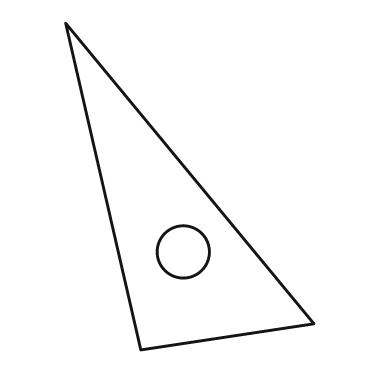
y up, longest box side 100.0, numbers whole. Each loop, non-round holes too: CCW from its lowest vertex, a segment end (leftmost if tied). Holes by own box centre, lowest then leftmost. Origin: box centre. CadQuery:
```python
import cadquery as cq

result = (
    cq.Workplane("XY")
    .moveTo(-15.0, -50.0)
    .lineTo(38.0, -42.0)
    .lineTo(-38.0, 50.0)
    .close()
    .moveTo(-2.0, -20.0)
    .circle(8.0)
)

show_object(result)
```